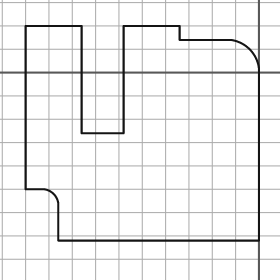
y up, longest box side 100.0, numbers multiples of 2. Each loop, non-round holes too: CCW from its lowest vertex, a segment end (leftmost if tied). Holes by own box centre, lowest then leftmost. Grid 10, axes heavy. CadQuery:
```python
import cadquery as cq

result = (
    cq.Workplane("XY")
    .moveTo(-86.0, -72.0)
    .lineTo(0.0, -72.0)
    .lineTo(0.0, 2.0)
    .threePointArc((-4.0, 10.0), (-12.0, 14.0))
    .lineTo(-34.0, 14.0)
    .lineTo(-34.0, 20.0)
    .lineTo(-58.0, 20.0)
    .lineTo(-58.0, -26.0)
    .lineTo(-76.0, -26.0)
    .lineTo(-76.0, 20.0)
    .lineTo(-100.0, 20.0)
    .lineTo(-100.0, -50.0)
    .lineTo(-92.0, -50.0)
    .threePointArc((-88.0, -52.0), (-86.0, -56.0))
    .close()
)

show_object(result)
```